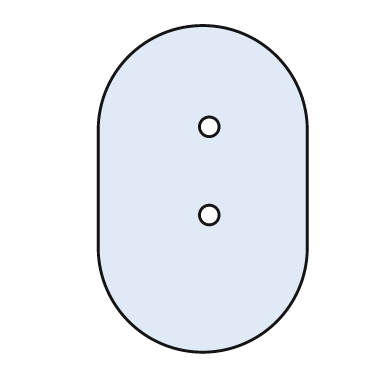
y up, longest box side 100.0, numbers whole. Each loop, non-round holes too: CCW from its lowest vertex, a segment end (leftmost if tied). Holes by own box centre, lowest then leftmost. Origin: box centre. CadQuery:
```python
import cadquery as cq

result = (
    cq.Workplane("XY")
    .moveTo(-32.0, -18.0)
    .threePointArc((0.0, -50.0), (32.0, -18.0))
    .lineTo(32.0, 18.0)
    .threePointArc((0.0, 50.0), (-32.0, 18.0))
    .close()
    .moveTo(2.0, -8.0)
    .circle(3.0)
    .moveTo(2.0, 19.0)
    .circle(3.0)
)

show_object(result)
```